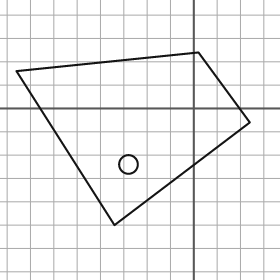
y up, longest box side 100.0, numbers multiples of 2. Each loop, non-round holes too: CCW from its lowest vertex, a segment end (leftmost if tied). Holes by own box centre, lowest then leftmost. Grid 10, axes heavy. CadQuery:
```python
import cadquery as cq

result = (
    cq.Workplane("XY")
    .moveTo(-34.0, -50.0)
    .lineTo(24.0, -6.0)
    .lineTo(2.0, 24.0)
    .lineTo(-76.0, 16.0)
    .close()
    .moveTo(-28.0, -24.0)
    .circle(4.0)
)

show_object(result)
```